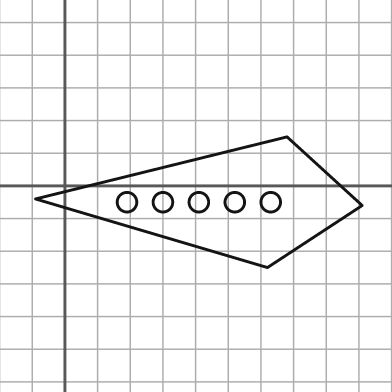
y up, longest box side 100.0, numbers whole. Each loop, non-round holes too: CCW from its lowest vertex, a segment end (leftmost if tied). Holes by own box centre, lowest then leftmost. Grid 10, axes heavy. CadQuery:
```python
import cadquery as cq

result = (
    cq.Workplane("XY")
    .moveTo(62.0, -25.0)
    .lineTo(91.0, -6.0)
    .lineTo(68.0, 15.0)
    .lineTo(-9.0, -4.0)
    .close()
    .moveTo(19.0, -5.0)
    .circle(3.0)
    .moveTo(30.0, -5.0)
    .circle(3.0)
    .moveTo(41.0, -5.0)
    .circle(3.0)
    .moveTo(52.0, -5.0)
    .circle(3.0)
    .moveTo(63.0, -5.0)
    .circle(3.0)
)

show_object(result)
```